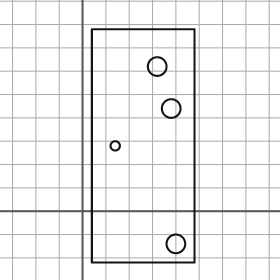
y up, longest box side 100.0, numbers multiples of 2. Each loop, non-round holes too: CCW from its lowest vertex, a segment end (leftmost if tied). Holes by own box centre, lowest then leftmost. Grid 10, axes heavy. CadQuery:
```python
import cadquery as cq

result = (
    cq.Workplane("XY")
    .moveTo(4.0, -22.0)
    .lineTo(48.0, -22.0)
    .lineTo(48.0, 78.0)
    .lineTo(4.0, 78.0)
    .close()
    .moveTo(40.0, -14.0)
    .circle(4.0)
    .moveTo(14.0, 28.0)
    .circle(2.0)
    .moveTo(38.0, 44.0)
    .circle(4.0)
    .moveTo(32.0, 62.0)
    .circle(4.0)
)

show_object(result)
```